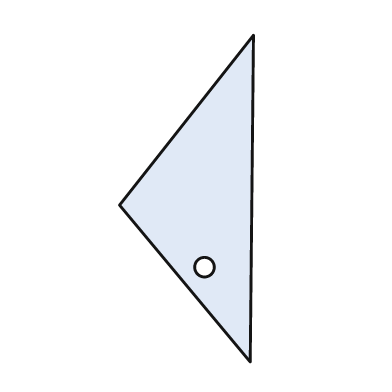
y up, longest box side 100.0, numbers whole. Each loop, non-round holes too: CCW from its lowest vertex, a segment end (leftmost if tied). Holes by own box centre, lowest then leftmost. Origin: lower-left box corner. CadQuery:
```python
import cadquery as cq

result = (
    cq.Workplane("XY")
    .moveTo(40.0, 0.0)
    .lineTo(41.0, 100.0)
    .lineTo(0.0, 48.0)
    .close()
    .moveTo(26.0, 29.0)
    .circle(3.0)
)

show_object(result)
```